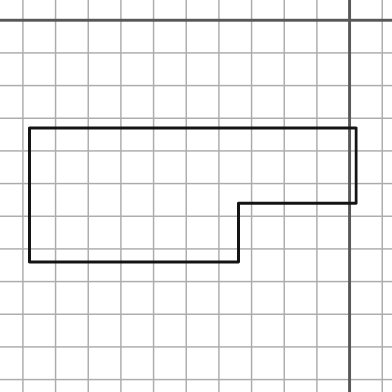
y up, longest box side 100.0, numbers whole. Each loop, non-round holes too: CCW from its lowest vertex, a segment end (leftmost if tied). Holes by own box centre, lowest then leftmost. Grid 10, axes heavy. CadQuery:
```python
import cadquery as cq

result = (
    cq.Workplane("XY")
    .moveTo(-98.0, -74.0)
    .lineTo(-34.0, -74.0)
    .lineTo(-34.0, -56.0)
    .lineTo(2.0, -56.0)
    .lineTo(2.0, -33.0)
    .lineTo(-98.0, -33.0)
    .close()
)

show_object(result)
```